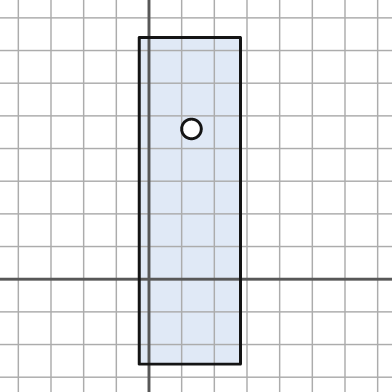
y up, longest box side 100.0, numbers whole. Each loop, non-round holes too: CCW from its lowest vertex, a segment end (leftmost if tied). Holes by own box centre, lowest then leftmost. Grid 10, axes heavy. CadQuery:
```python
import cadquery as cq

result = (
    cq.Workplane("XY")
    .moveTo(-3.0, -26.0)
    .lineTo(28.0, -26.0)
    .lineTo(28.0, 74.0)
    .lineTo(-3.0, 74.0)
    .close()
    .moveTo(13.0, 46.0)
    .circle(3.0)
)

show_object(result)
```